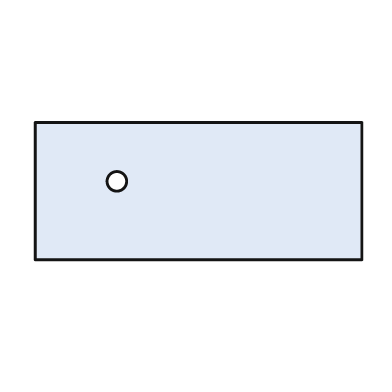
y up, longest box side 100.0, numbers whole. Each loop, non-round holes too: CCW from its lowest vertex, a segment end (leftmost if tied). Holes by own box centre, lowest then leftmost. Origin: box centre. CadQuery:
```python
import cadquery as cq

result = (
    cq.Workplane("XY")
    .moveTo(-50.0, -21.0)
    .lineTo(50.0, -21.0)
    .lineTo(50.0, 21.0)
    .lineTo(-50.0, 21.0)
    .close()
    .moveTo(-25.0, 3.0)
    .circle(3.0)
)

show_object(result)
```